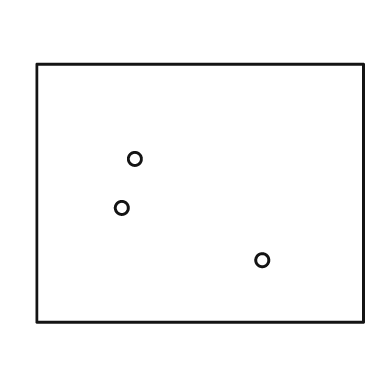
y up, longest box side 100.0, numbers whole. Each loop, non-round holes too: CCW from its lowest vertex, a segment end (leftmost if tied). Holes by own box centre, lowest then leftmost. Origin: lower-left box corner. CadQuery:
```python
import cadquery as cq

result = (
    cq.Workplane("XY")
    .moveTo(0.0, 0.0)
    .lineTo(100.0, 0.0)
    .lineTo(100.0, 79.0)
    .lineTo(0.0, 79.0)
    .close()
    .moveTo(69.0, 19.0)
    .circle(2.0)
    .moveTo(26.0, 35.0)
    .circle(2.0)
    .moveTo(30.0, 50.0)
    .circle(2.0)
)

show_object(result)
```